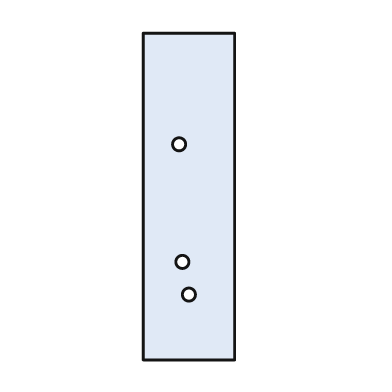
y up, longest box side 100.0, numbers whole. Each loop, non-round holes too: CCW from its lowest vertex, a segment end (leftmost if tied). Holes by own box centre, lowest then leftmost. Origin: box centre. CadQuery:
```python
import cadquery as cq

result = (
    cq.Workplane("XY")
    .moveTo(-14.0, -50.0)
    .lineTo(14.0, -50.0)
    .lineTo(14.0, 50.0)
    .lineTo(-14.0, 50.0)
    .close()
    .moveTo(0.0, -30.0)
    .circle(2.0)
    .moveTo(-2.0, -20.0)
    .circle(2.0)
    .moveTo(-3.0, 16.0)
    .circle(2.0)
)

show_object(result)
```